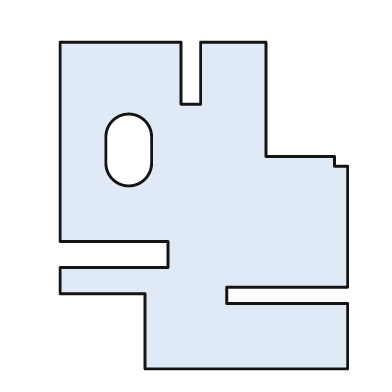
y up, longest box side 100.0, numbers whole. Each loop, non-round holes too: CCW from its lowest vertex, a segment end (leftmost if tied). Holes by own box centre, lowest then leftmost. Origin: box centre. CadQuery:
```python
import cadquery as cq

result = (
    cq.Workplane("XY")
    .moveTo(-18.0, -50.0)
    .lineTo(44.0, -50.0)
    .lineTo(44.0, -30.0)
    .lineTo(7.0, -30.0)
    .lineTo(7.0, -25.0)
    .lineTo(44.0, -25.0)
    .lineTo(44.0, 12.0)
    .lineTo(40.0, 12.0)
    .lineTo(40.0, 15.0)
    .lineTo(19.0, 15.0)
    .lineTo(19.0, 50.0)
    .lineTo(-1.0, 50.0)
    .lineTo(-1.0, 31.0)
    .lineTo(-7.0, 31.0)
    .lineTo(-7.0, 50.0)
    .lineTo(-44.0, 50.0)
    .lineTo(-44.0, -11.0)
    .lineTo(-11.0, -11.0)
    .lineTo(-11.0, -19.0)
    .lineTo(-44.0, -19.0)
    .lineTo(-44.0, -27.0)
    .lineTo(-18.0, -27.0)
    .close()
    .moveTo(-30.0, 13.0)
    .threePointArc((-23.0, 6.0), (-16.0, 13.0))
    .lineTo(-16.0, 21.0)
    .threePointArc((-23.0, 28.0), (-30.0, 21.0))
    .close()
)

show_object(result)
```